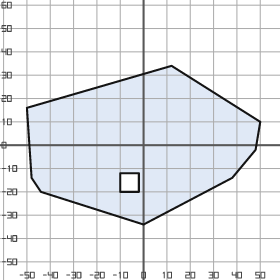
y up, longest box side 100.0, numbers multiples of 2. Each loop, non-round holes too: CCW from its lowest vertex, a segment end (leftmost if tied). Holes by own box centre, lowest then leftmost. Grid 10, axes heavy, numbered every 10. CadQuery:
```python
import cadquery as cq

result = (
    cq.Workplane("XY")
    .moveTo(0.0, -34.0)
    .lineTo(38.0, -14.0)
    .lineTo(48.0, -2.0)
    .lineTo(50.0, 10.0)
    .lineTo(12.0, 34.0)
    .lineTo(-50.0, 16.0)
    .lineTo(-48.0, -14.0)
    .lineTo(-44.0, -20.0)
    .close()
    .moveTo(-10.0, -20.0)
    .lineTo(-2.0, -20.0)
    .lineTo(-2.0, -12.0)
    .lineTo(-10.0, -12.0)
    .close()
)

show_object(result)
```